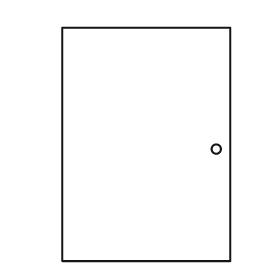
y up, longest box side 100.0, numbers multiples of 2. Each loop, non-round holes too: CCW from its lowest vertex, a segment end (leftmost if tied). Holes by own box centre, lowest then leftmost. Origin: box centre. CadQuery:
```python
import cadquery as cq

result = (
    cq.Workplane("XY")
    .moveTo(-36.0, -50.0)
    .lineTo(36.0, -50.0)
    .lineTo(36.0, 50.0)
    .lineTo(-36.0, 50.0)
    .close()
    .moveTo(30.0, -2.0)
    .circle(2.0)
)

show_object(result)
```